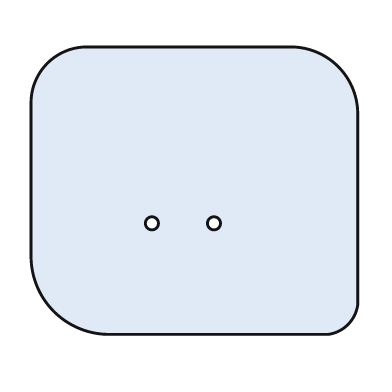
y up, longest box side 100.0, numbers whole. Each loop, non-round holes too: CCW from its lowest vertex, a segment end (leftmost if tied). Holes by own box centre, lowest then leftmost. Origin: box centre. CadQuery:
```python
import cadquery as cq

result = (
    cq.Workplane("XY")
    .moveTo(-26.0, -44.0)
    .lineTo(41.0, -44.0)
    .threePointArc((47.0, -41.0), (50.0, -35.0))
    .lineTo(50.0, 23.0)
    .threePointArc((44.0, 38.0), (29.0, 44.0))
    .lineTo(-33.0, 44.0)
    .threePointArc((-45.0, 39.0), (-50.0, 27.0))
    .lineTo(-50.0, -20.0)
    .threePointArc((-43.0, -37.0), (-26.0, -44.0))
    .close()
    .moveTo(-13.0, -10.0)
    .circle(2.0)
    .moveTo(6.0, -10.0)
    .circle(2.0)
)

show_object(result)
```